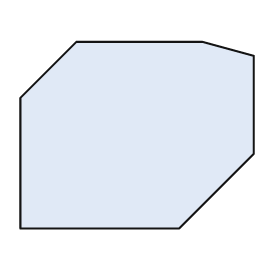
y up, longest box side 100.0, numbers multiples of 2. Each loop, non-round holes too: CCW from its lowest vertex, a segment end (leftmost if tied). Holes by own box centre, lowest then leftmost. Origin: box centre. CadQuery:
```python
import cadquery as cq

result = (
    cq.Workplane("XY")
    .moveTo(-50.0, -40.0)
    .lineTo(18.0, -40.0)
    .lineTo(50.0, -8.0)
    .lineTo(50.0, 34.0)
    .lineTo(28.0, 40.0)
    .lineTo(-26.0, 40.0)
    .lineTo(-50.0, 16.0)
    .close()
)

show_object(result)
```